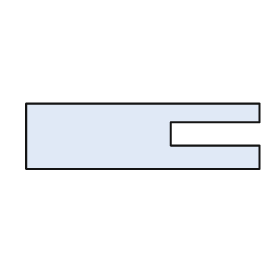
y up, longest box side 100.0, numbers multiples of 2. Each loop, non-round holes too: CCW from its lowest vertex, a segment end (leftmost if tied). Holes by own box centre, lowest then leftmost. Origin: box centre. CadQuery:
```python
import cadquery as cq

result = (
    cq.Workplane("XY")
    .moveTo(-50.0, -14.0)
    .lineTo(50.0, -14.0)
    .lineTo(50.0, -4.0)
    .lineTo(12.0, -4.0)
    .lineTo(12.0, 6.0)
    .lineTo(50.0, 6.0)
    .lineTo(50.0, 14.0)
    .lineTo(-50.0, 14.0)
    .close()
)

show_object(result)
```